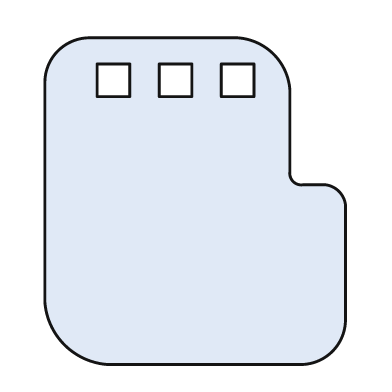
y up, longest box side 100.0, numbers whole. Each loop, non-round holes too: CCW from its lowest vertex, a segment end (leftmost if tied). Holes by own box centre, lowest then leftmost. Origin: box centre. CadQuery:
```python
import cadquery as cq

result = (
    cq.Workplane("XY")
    .moveTo(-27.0, -50.0)
    .lineTo(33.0, -50.0)
    .threePointArc((42.0, -46.0), (46.0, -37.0))
    .lineTo(46.0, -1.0)
    .threePointArc((44.0, 3.0), (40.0, 5.0))
    .lineTo(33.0, 5.0)
    .threePointArc((30.0, 6.0), (29.0, 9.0))
    .lineTo(29.0, 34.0)
    .threePointArc((24.0, 45.0), (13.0, 50.0))
    .lineTo(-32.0, 50.0)
    .threePointArc((-42.0, 46.0), (-46.0, 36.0))
    .lineTo(-46.0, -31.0)
    .threePointArc((-40.0, -44.0), (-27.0, -50.0))
    .close()
    .moveTo(-30.0, 32.0)
    .lineTo(-20.0, 32.0)
    .lineTo(-20.0, 42.0)
    .lineTo(-30.0, 42.0)
    .close()
    .moveTo(-11.0, 32.0)
    .lineTo(-1.0, 32.0)
    .lineTo(-1.0, 42.0)
    .lineTo(-11.0, 42.0)
    .close()
    .moveTo(8.0, 32.0)
    .lineTo(18.0, 32.0)
    .lineTo(18.0, 42.0)
    .lineTo(8.0, 42.0)
    .close()
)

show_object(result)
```